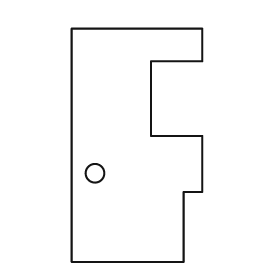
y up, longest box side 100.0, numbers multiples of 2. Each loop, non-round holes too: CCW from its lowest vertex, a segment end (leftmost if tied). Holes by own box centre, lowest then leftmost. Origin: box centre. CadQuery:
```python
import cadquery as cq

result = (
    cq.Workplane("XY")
    .moveTo(-28.0, -50.0)
    .lineTo(20.0, -50.0)
    .lineTo(20.0, -20.0)
    .lineTo(28.0, -20.0)
    .lineTo(28.0, 4.0)
    .lineTo(6.0, 4.0)
    .lineTo(6.0, 36.0)
    .lineTo(28.0, 36.0)
    .lineTo(28.0, 50.0)
    .lineTo(-28.0, 50.0)
    .close()
    .moveTo(-18.0, -12.0)
    .circle(4.0)
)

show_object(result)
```